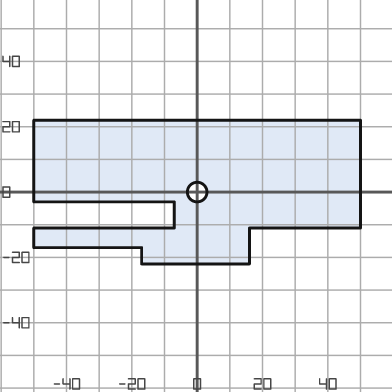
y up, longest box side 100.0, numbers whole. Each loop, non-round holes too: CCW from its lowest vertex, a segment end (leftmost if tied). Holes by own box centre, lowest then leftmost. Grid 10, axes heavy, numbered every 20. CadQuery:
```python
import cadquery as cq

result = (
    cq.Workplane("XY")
    .moveTo(-17.0, -22.0)
    .lineTo(16.0, -22.0)
    .lineTo(16.0, -11.0)
    .lineTo(50.0, -11.0)
    .lineTo(50.0, 22.0)
    .lineTo(-50.0, 22.0)
    .lineTo(-50.0, -3.0)
    .lineTo(-7.0, -3.0)
    .lineTo(-7.0, -11.0)
    .lineTo(-50.0, -11.0)
    .lineTo(-50.0, -17.0)
    .lineTo(-17.0, -17.0)
    .close()
    .moveTo(0.0, 0.0)
    .circle(3.0)
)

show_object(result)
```